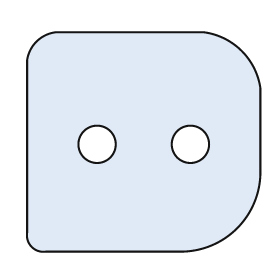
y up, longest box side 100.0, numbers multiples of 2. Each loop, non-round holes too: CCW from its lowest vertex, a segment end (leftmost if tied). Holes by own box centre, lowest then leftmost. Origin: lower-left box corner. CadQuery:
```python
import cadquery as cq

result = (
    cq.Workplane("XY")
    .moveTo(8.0, 0.0)
    .lineTo(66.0, 0.0)
    .threePointArc((90.0, 10.0), (100.0, 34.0))
    .lineTo(100.0, 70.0)
    .threePointArc((92.0, 86.0), (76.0, 94.0))
    .lineTo(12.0, 94.0)
    .threePointArc((4.0, 90.0), (0.0, 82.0))
    .lineTo(0.0, 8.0)
    .threePointArc((2.0, 2.0), (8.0, 0.0))
    .close()
    .moveTo(30.0, 46.0)
    .circle(8.0)
    .moveTo(70.0, 46.0)
    .circle(8.0)
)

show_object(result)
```